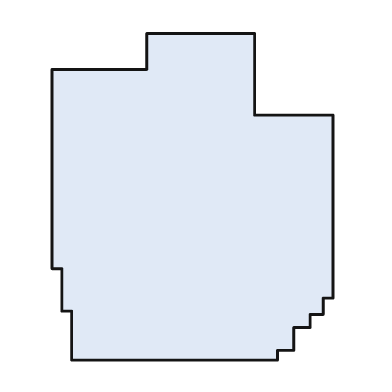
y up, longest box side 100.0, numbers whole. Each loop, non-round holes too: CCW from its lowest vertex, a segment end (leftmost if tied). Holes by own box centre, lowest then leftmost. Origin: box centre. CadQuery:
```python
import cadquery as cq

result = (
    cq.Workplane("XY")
    .moveTo(-37.0, -50.0)
    .lineTo(26.0, -50.0)
    .lineTo(26.0, -47.0)
    .lineTo(31.0, -47.0)
    .lineTo(31.0, -40.0)
    .lineTo(36.0, -40.0)
    .lineTo(36.0, -36.0)
    .lineTo(40.0, -36.0)
    .lineTo(40.0, -31.0)
    .lineTo(43.0, -31.0)
    .lineTo(43.0, 25.0)
    .lineTo(19.0, 25.0)
    .lineTo(19.0, 50.0)
    .lineTo(-14.0, 50.0)
    .lineTo(-14.0, 39.0)
    .lineTo(-43.0, 39.0)
    .lineTo(-43.0, -22.0)
    .lineTo(-40.0, -22.0)
    .lineTo(-40.0, -35.0)
    .lineTo(-37.0, -35.0)
    .close()
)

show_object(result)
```